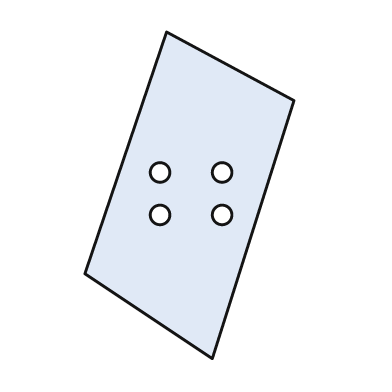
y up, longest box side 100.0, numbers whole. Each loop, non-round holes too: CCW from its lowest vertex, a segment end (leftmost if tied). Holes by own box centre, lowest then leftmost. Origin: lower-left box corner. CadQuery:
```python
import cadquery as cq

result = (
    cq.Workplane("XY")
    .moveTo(39.0, 0.0)
    .lineTo(64.0, 79.0)
    .lineTo(25.0, 100.0)
    .lineTo(0.0, 26.0)
    .close()
    .moveTo(23.0, 44.0)
    .circle(3.0)
    .moveTo(42.0, 44.0)
    .circle(3.0)
    .moveTo(23.0, 57.0)
    .circle(3.0)
    .moveTo(42.0, 57.0)
    .circle(3.0)
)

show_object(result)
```